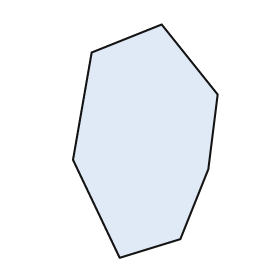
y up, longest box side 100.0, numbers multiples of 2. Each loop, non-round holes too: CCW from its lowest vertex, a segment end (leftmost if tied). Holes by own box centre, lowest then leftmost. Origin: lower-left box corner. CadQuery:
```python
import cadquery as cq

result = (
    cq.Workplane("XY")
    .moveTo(20.0, 0.0)
    .lineTo(46.0, 8.0)
    .lineTo(58.0, 38.0)
    .lineTo(62.0, 70.0)
    .lineTo(38.0, 100.0)
    .lineTo(8.0, 88.0)
    .lineTo(0.0, 42.0)
    .close()
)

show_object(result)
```